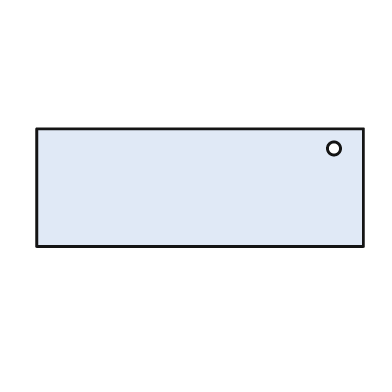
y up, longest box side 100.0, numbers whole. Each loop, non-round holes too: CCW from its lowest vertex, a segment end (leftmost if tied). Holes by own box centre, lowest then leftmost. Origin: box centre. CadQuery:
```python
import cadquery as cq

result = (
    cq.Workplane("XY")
    .moveTo(-50.0, -18.0)
    .lineTo(50.0, -18.0)
    .lineTo(50.0, 18.0)
    .lineTo(-50.0, 18.0)
    .close()
    .moveTo(41.0, 12.0)
    .circle(2.0)
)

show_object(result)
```